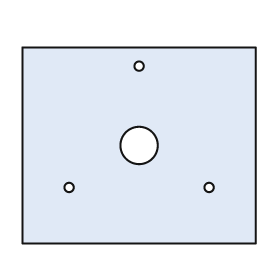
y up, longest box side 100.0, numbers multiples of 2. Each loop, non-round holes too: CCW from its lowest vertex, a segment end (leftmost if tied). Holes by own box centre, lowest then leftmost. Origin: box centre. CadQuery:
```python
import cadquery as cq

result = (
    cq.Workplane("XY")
    .moveTo(-50.0, -42.0)
    .lineTo(50.0, -42.0)
    .lineTo(50.0, 42.0)
    .lineTo(-50.0, 42.0)
    .close()
    .moveTo(-30.0, -18.0)
    .circle(2.0)
    .moveTo(30.0, -18.0)
    .circle(2.0)
    .moveTo(0.0, 0.0)
    .circle(8.0)
    .moveTo(0.0, 34.0)
    .circle(2.0)
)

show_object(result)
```